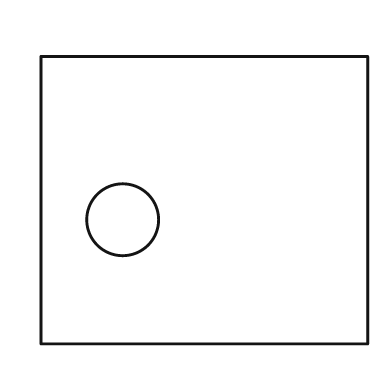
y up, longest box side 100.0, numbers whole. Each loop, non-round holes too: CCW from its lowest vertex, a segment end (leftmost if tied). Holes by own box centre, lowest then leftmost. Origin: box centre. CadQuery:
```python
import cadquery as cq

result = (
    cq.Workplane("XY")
    .moveTo(-50.0, -44.0)
    .lineTo(50.0, -44.0)
    .lineTo(50.0, 44.0)
    .lineTo(-50.0, 44.0)
    .close()
    .moveTo(-25.0, -6.0)
    .circle(11.0)
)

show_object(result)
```